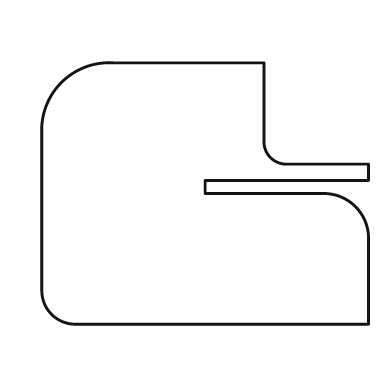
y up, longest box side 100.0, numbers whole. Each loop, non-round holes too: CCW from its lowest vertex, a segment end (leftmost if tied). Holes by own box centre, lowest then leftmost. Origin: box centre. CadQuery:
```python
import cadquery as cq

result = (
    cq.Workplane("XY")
    .moveTo(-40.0, -40.0)
    .lineTo(50.0, -40.0)
    .lineTo(50.0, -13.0)
    .threePointArc((46.0, -4.0), (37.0, 0.0))
    .lineTo(0.0, 0.0)
    .lineTo(0.0, 4.0)
    .lineTo(50.0, 4.0)
    .lineTo(50.0, 9.0)
    .lineTo(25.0, 9.0)
    .threePointArc((20.0, 11.0), (18.0, 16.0))
    .lineTo(18.0, 40.0)
    .lineTo(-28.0, 40.0)
    .threePointArc((-44.0, 34.0), (-50.0, 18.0))
    .lineTo(-50.0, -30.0)
    .threePointArc((-47.0, -37.0), (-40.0, -40.0))
    .close()
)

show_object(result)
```